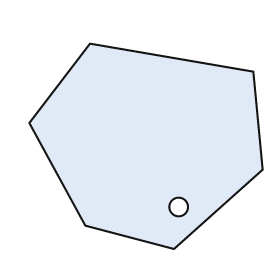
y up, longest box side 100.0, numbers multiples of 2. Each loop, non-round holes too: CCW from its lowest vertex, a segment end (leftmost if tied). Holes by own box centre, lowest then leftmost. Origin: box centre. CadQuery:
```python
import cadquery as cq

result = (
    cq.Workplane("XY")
    .moveTo(12.0, -44.0)
    .lineTo(50.0, -10.0)
    .lineTo(46.0, 32.0)
    .lineTo(-24.0, 44.0)
    .lineTo(-50.0, 10.0)
    .lineTo(-26.0, -34.0)
    .close()
    .moveTo(14.0, -26.0)
    .circle(4.0)
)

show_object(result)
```